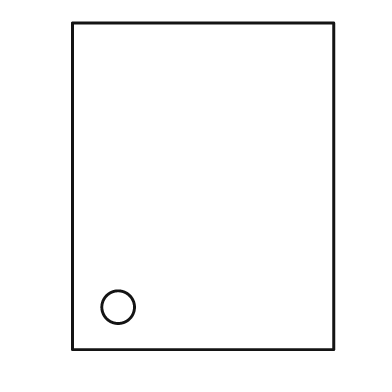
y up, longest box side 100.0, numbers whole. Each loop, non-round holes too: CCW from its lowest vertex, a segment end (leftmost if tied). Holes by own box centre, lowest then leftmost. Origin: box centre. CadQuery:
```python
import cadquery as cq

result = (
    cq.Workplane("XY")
    .moveTo(-40.0, -50.0)
    .lineTo(40.0, -50.0)
    .lineTo(40.0, 50.0)
    .lineTo(-40.0, 50.0)
    .close()
    .moveTo(-26.0, -37.0)
    .circle(5.0)
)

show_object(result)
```